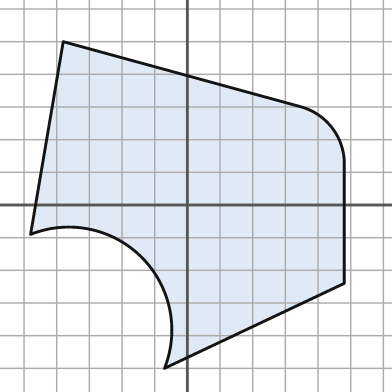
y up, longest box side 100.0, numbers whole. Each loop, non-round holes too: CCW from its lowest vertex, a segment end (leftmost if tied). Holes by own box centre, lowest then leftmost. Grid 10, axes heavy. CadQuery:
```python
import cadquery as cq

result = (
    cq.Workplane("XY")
    .moveTo(-7.0, -50.0)
    .lineTo(48.0, -24.0)
    .lineTo(48.0, 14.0)
    .threePointArc((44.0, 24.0), (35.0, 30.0))
    .lineTo(-38.0, 50.0)
    .lineTo(-48.0, -9.0)
    .threePointArc((-14.0, -16.0), (-7.0, -50.0))
    .close()
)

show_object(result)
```